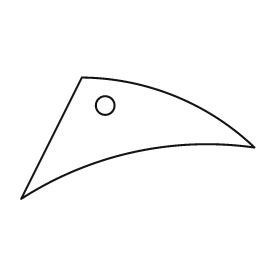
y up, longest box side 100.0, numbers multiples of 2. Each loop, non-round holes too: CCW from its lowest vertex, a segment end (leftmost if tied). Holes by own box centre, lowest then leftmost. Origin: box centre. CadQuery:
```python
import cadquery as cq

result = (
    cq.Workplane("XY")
    .moveTo(-50.0, -26.0)
    .threePointArc((-2.0, -6.0), (50.0, -4.0))
    .threePointArc((16.0, 18.0), (-24.0, 26.0))
    .close()
    .moveTo(-14.0, 14.0)
    .circle(4.0)
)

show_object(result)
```